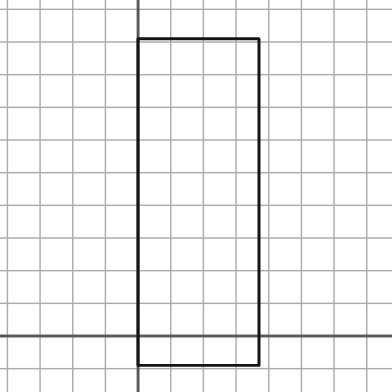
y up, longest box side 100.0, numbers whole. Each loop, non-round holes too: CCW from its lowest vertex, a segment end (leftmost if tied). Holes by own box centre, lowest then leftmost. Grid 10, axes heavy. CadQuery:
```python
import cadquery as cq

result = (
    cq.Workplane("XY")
    .moveTo(0.0, -9.0)
    .lineTo(37.0, -9.0)
    .lineTo(37.0, 91.0)
    .lineTo(0.0, 91.0)
    .close()
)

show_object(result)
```